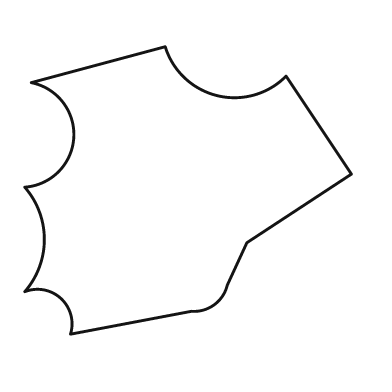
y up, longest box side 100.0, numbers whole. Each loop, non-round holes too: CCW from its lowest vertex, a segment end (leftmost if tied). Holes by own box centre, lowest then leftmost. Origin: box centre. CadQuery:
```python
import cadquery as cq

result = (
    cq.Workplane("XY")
    .moveTo(-36.0, -44.0)
    .lineTo(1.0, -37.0)
    .threePointArc((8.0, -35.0), (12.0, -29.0))
    .lineTo(18.0, -16.0)
    .lineTo(50.0, 5.0)
    .lineTo(30.0, 35.0)
    .threePointArc((9.0, 29.0), (-7.0, 44.0))
    .lineTo(-48.0, 33.0)
    .threePointArc((-35.0, 16.0), (-50.0, 1.0))
    .threePointArc((-44.0, -15.0), (-50.0, -31.0))
    .threePointArc((-39.0, -33.0), (-36.0, -44.0))
    .close()
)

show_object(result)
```